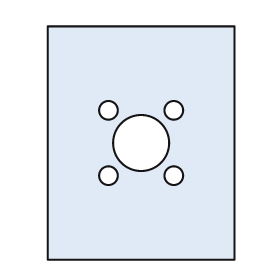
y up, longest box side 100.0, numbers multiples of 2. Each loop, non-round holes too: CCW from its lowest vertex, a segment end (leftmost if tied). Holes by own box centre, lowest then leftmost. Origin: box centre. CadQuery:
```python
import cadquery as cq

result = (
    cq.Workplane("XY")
    .moveTo(-40.0, -50.0)
    .lineTo(40.0, -50.0)
    .lineTo(40.0, 50.0)
    .lineTo(-40.0, 50.0)
    .close()
    .moveTo(-14.0, -14.0)
    .circle(4.0)
    .moveTo(14.0, -14.0)
    .circle(4.0)
    .moveTo(0.0, 0.0)
    .circle(12.0)
    .moveTo(-14.0, 14.0)
    .circle(4.0)
    .moveTo(14.0, 14.0)
    .circle(4.0)
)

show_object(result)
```